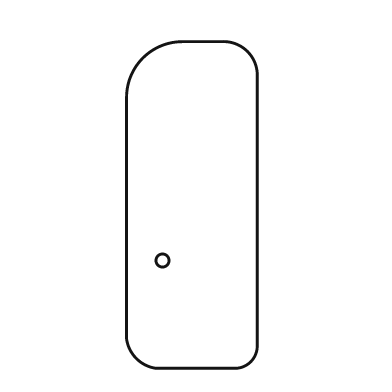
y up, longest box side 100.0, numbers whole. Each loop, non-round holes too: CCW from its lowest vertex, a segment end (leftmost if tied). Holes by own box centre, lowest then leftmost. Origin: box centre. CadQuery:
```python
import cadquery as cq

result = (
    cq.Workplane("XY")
    .moveTo(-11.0, -50.0)
    .lineTo(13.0, -50.0)
    .threePointArc((18.0, -48.0), (20.0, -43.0))
    .lineTo(20.0, 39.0)
    .threePointArc((17.0, 47.0), (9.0, 50.0))
    .lineTo(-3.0, 50.0)
    .threePointArc((-15.0, 45.0), (-20.0, 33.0))
    .lineTo(-20.0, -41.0)
    .threePointArc((-17.0, -47.0), (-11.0, -50.0))
    .close()
    .moveTo(-9.0, -17.0)
    .circle(2.0)
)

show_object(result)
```